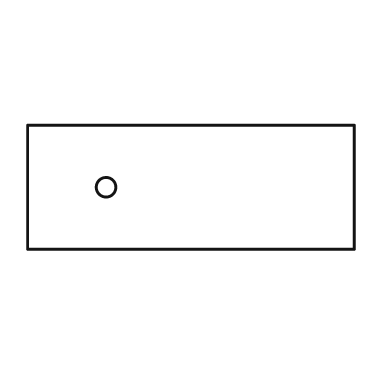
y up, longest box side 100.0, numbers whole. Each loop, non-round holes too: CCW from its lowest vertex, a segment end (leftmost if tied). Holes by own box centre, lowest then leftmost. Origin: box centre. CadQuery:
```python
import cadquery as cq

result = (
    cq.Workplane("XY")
    .moveTo(-50.0, -19.0)
    .lineTo(50.0, -19.0)
    .lineTo(50.0, 19.0)
    .lineTo(-50.0, 19.0)
    .close()
    .moveTo(-26.0, 0.0)
    .circle(3.0)
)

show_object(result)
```